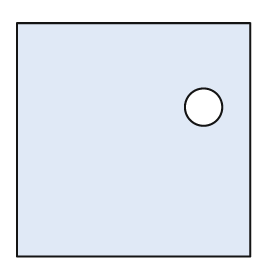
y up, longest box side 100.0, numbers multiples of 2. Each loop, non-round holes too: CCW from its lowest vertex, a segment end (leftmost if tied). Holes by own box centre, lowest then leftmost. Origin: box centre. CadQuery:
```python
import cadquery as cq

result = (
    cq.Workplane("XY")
    .moveTo(-50.0, -50.0)
    .lineTo(50.0, -50.0)
    .lineTo(50.0, 50.0)
    .lineTo(-50.0, 50.0)
    .close()
    .moveTo(30.0, 14.0)
    .circle(8.0)
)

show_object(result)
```